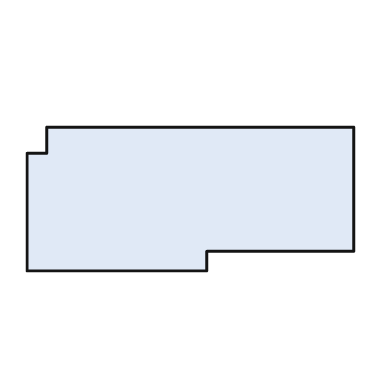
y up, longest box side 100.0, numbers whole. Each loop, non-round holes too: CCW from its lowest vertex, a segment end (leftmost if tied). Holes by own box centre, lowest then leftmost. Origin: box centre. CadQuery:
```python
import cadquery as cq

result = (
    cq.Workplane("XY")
    .moveTo(-50.0, -22.0)
    .lineTo(5.0, -22.0)
    .lineTo(5.0, -16.0)
    .lineTo(50.0, -16.0)
    .lineTo(50.0, 22.0)
    .lineTo(-44.0, 22.0)
    .lineTo(-44.0, 14.0)
    .lineTo(-50.0, 14.0)
    .close()
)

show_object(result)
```